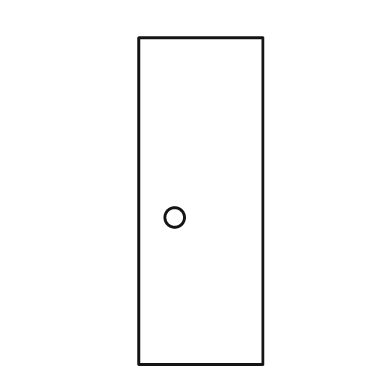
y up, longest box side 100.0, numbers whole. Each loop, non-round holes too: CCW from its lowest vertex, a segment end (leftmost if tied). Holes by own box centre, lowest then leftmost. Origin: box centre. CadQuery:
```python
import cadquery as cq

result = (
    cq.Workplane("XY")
    .moveTo(-19.0, -50.0)
    .lineTo(19.0, -50.0)
    .lineTo(19.0, 50.0)
    .lineTo(-19.0, 50.0)
    .close()
    .moveTo(-8.0, -5.0)
    .circle(3.0)
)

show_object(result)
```